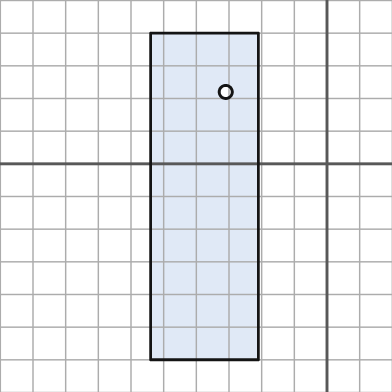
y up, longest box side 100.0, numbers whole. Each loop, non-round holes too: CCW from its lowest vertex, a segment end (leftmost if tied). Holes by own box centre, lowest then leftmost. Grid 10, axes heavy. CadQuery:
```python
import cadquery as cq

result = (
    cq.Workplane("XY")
    .moveTo(-54.0, -60.0)
    .lineTo(-21.0, -60.0)
    .lineTo(-21.0, 40.0)
    .lineTo(-54.0, 40.0)
    .close()
    .moveTo(-31.0, 22.0)
    .circle(2.0)
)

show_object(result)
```